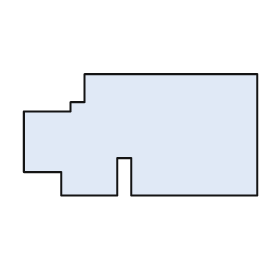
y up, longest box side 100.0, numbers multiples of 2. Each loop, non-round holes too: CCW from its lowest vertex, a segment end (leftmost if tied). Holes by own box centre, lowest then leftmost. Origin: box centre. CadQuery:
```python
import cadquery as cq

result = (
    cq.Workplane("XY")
    .moveTo(-34.0, -26.0)
    .lineTo(-10.0, -26.0)
    .lineTo(-10.0, -10.0)
    .lineTo(-4.0, -10.0)
    .lineTo(-4.0, -26.0)
    .lineTo(50.0, -26.0)
    .lineTo(50.0, 26.0)
    .lineTo(-24.0, 26.0)
    .lineTo(-24.0, 14.0)
    .lineTo(-30.0, 14.0)
    .lineTo(-30.0, 10.0)
    .lineTo(-50.0, 10.0)
    .lineTo(-50.0, -16.0)
    .lineTo(-34.0, -16.0)
    .close()
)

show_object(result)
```